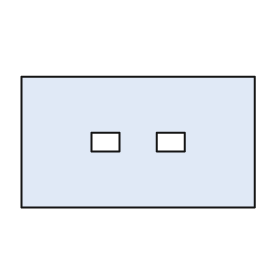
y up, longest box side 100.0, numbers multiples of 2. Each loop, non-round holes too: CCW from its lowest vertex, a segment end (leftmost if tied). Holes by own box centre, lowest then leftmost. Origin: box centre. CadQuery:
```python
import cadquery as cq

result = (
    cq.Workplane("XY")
    .moveTo(-50.0, -28.0)
    .lineTo(50.0, -28.0)
    .lineTo(50.0, 28.0)
    .lineTo(-50.0, 28.0)
    .close()
    .moveTo(-20.0, -4.0)
    .lineTo(-8.0, -4.0)
    .lineTo(-8.0, 4.0)
    .lineTo(-20.0, 4.0)
    .close()
    .moveTo(8.0, -4.0)
    .lineTo(20.0, -4.0)
    .lineTo(20.0, 4.0)
    .lineTo(8.0, 4.0)
    .close()
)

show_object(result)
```